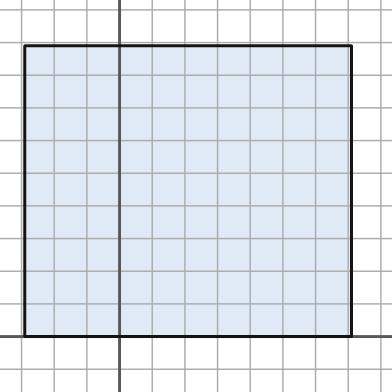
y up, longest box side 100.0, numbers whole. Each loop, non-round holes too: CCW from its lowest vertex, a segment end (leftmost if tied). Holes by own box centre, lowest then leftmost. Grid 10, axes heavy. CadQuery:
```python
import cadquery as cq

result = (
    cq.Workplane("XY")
    .moveTo(-29.0, 0.0)
    .lineTo(71.0, 0.0)
    .lineTo(71.0, 89.0)
    .lineTo(-29.0, 89.0)
    .close()
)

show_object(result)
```